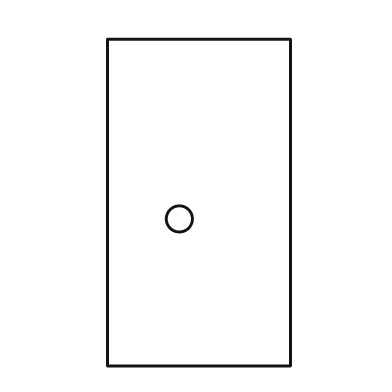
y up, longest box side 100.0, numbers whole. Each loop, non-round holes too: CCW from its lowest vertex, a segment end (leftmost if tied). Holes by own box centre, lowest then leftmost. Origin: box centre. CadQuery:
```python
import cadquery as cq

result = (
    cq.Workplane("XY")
    .moveTo(-28.0, -50.0)
    .lineTo(28.0, -50.0)
    .lineTo(28.0, 50.0)
    .lineTo(-28.0, 50.0)
    .close()
    .moveTo(-6.0, -5.0)
    .circle(4.0)
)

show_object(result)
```